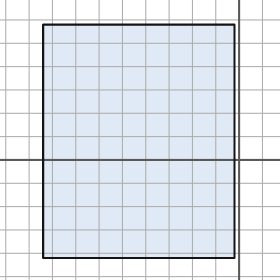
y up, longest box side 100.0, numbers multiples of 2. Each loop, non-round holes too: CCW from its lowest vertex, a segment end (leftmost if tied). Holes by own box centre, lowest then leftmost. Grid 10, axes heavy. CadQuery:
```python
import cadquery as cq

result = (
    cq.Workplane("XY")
    .moveTo(-84.0, -42.0)
    .lineTo(-2.0, -42.0)
    .lineTo(-2.0, 58.0)
    .lineTo(-84.0, 58.0)
    .close()
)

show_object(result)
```